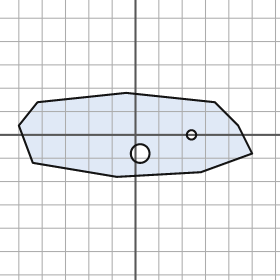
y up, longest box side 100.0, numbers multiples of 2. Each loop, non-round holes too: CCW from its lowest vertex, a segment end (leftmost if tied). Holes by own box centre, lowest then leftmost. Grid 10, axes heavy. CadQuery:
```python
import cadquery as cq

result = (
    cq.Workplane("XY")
    .moveTo(-8.0, -18.0)
    .lineTo(28.0, -16.0)
    .lineTo(50.0, -8.0)
    .lineTo(44.0, 4.0)
    .lineTo(34.0, 14.0)
    .lineTo(-4.0, 18.0)
    .lineTo(-42.0, 14.0)
    .lineTo(-50.0, 4.0)
    .lineTo(-44.0, -12.0)
    .close()
    .moveTo(2.0, -8.0)
    .circle(4.0)
    .moveTo(24.0, 0.0)
    .circle(2.0)
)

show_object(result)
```